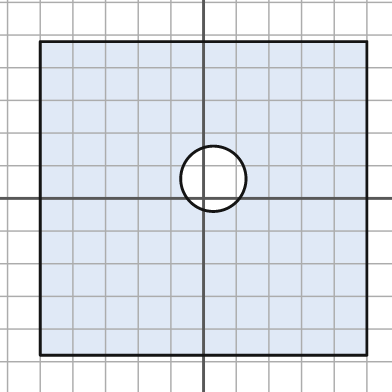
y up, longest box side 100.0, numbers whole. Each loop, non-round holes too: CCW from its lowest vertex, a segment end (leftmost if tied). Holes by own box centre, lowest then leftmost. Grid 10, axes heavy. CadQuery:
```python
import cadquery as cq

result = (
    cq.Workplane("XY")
    .moveTo(-50.0, -48.0)
    .lineTo(50.0, -48.0)
    .lineTo(50.0, 48.0)
    .lineTo(-50.0, 48.0)
    .close()
    .moveTo(3.0, 6.0)
    .circle(10.0)
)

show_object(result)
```